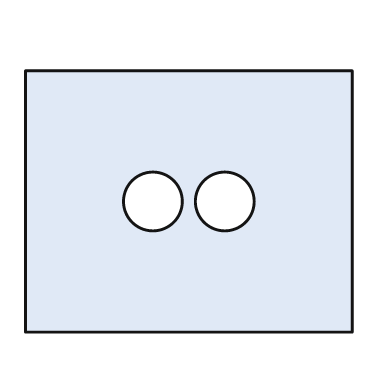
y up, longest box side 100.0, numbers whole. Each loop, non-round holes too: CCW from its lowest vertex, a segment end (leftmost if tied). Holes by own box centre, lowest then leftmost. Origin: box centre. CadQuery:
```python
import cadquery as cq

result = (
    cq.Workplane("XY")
    .moveTo(-50.0, -40.0)
    .lineTo(50.0, -40.0)
    .lineTo(50.0, 40.0)
    .lineTo(-50.0, 40.0)
    .close()
    .moveTo(-11.0, 0.0)
    .circle(9.0)
    .moveTo(11.0, 0.0)
    .circle(9.0)
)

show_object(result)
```